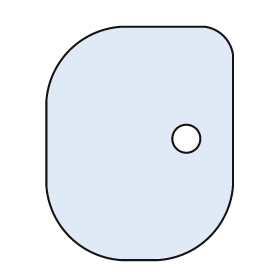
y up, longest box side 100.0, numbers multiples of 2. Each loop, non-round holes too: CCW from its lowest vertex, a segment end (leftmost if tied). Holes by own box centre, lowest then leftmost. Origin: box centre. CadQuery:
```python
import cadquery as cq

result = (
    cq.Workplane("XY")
    .moveTo(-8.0, -50.0)
    .lineTo(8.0, -50.0)
    .threePointArc((30.0, -40.0), (40.0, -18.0))
    .lineTo(40.0, 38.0)
    .threePointArc((36.0, 46.0), (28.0, 50.0))
    .lineTo(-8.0, 50.0)
    .threePointArc((-30.0, 40.0), (-40.0, 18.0))
    .lineTo(-40.0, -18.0)
    .threePointArc((-30.0, -40.0), (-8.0, -50.0))
    .close()
    .moveTo(20.0, 2.0)
    .circle(6.0)
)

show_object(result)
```